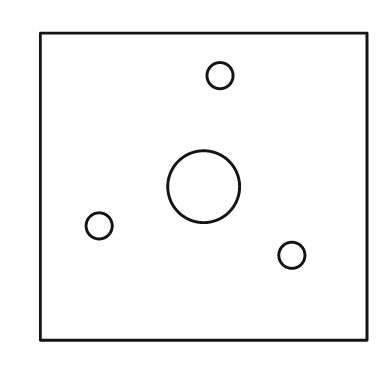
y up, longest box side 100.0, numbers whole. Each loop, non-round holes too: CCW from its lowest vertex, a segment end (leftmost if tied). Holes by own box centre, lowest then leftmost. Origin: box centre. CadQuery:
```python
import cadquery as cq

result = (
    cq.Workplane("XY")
    .moveTo(-50.0, -47.0)
    .lineTo(50.0, -47.0)
    .lineTo(50.0, 47.0)
    .lineTo(-50.0, 47.0)
    .close()
    .moveTo(27.0, -21.0)
    .circle(4.0)
    .moveTo(-32.0, -12.0)
    .circle(4.0)
    .moveTo(0.0, 0.0)
    .circle(11.0)
    .moveTo(5.0, 34.0)
    .circle(4.0)
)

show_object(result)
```